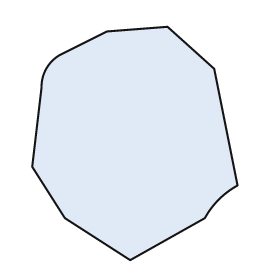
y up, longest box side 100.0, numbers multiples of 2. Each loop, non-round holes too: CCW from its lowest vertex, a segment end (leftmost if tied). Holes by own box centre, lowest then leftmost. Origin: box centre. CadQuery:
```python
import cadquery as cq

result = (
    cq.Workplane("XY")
    .moveTo(-2.0, -50.0)
    .lineTo(30.0, -32.0)
    .threePointArc((36.0, -24.0), (44.0, -18.0))
    .lineTo(34.0, 32.0)
    .lineTo(14.0, 50.0)
    .lineTo(-12.0, 48.0)
    .lineTo(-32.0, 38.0)
    .threePointArc((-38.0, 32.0), (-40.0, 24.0))
    .lineTo(-44.0, -10.0)
    .lineTo(-30.0, -32.0)
    .close()
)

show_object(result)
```